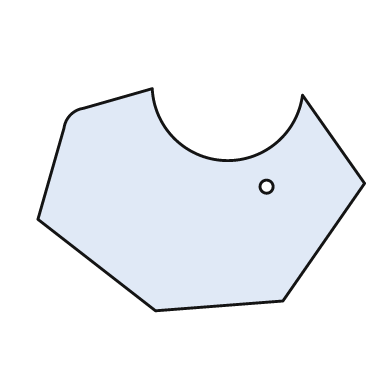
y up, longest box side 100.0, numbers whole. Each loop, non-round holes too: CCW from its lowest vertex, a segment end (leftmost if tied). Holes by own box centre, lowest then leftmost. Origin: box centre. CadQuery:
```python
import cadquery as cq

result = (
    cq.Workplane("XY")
    .moveTo(-14.0, -34.0)
    .lineTo(25.0, -31.0)
    .lineTo(50.0, 5.0)
    .lineTo(31.0, 32.0)
    .threePointArc((7.0, 12.0), (-15.0, 34.0))
    .lineTo(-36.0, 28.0)
    .threePointArc((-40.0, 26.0), (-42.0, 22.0))
    .lineTo(-50.0, -6.0)
    .close()
    .moveTo(20.0, 4.0)
    .circle(2.0)
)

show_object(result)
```